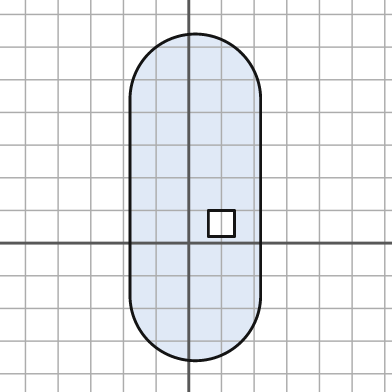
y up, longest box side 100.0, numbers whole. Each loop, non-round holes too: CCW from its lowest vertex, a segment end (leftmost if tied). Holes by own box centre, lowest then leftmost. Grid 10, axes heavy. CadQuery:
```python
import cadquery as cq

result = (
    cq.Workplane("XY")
    .moveTo(-18.0, -16.0)
    .threePointArc((2.0, -36.0), (22.0, -16.0))
    .lineTo(22.0, 44.0)
    .threePointArc((2.0, 64.0), (-18.0, 44.0))
    .close()
    .moveTo(6.0, 2.0)
    .lineTo(14.0, 2.0)
    .lineTo(14.0, 10.0)
    .lineTo(6.0, 10.0)
    .close()
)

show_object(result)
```